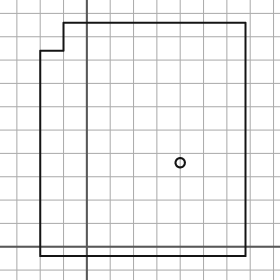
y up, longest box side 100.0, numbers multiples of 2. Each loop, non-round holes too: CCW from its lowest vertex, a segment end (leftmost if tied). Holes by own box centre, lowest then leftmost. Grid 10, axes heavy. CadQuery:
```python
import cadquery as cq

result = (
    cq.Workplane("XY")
    .moveTo(-20.0, -4.0)
    .lineTo(68.0, -4.0)
    .lineTo(68.0, 96.0)
    .lineTo(-10.0, 96.0)
    .lineTo(-10.0, 84.0)
    .lineTo(-20.0, 84.0)
    .close()
    .moveTo(40.0, 36.0)
    .circle(2.0)
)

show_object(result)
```